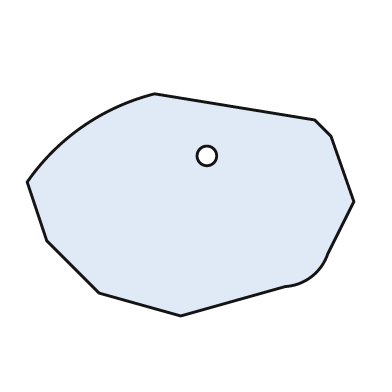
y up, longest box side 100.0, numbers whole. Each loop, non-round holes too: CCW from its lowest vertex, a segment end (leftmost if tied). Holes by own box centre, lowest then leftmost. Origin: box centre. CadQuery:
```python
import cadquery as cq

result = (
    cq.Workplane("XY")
    .moveTo(-3.0, -34.0)
    .lineTo(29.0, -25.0)
    .threePointArc((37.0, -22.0), (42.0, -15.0))
    .lineTo(50.0, 1.0)
    .lineTo(43.0, 21.0)
    .lineTo(38.0, 26.0)
    .lineTo(-11.0, 34.0)
    .threePointArc((-33.0, 24.0), (-50.0, 7.0))
    .lineTo(-44.0, -11.0)
    .lineTo(-28.0, -27.0)
    .close()
    .moveTo(5.0, 15.0)
    .circle(3.0)
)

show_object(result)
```